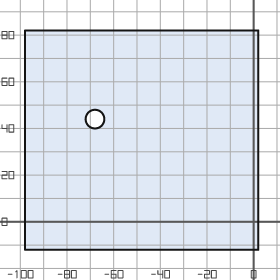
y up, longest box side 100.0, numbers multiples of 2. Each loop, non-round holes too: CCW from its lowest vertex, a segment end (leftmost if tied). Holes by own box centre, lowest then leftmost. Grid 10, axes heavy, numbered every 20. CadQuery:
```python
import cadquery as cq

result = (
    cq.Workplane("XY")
    .moveTo(-98.0, -12.0)
    .lineTo(2.0, -12.0)
    .lineTo(2.0, 82.0)
    .lineTo(-98.0, 82.0)
    .close()
    .moveTo(-68.0, 44.0)
    .circle(4.0)
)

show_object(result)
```